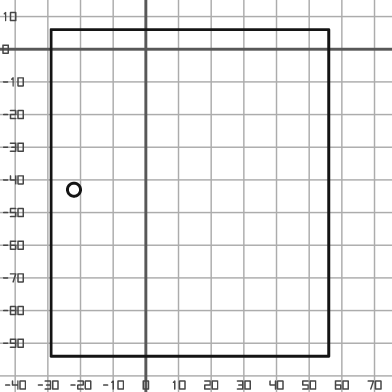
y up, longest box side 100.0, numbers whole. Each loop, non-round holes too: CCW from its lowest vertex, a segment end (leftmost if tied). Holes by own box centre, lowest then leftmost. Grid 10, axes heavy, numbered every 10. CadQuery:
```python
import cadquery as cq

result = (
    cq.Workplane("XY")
    .moveTo(-29.0, -94.0)
    .lineTo(56.0, -94.0)
    .lineTo(56.0, 6.0)
    .lineTo(-29.0, 6.0)
    .close()
    .moveTo(-22.0, -43.0)
    .circle(2.0)
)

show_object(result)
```